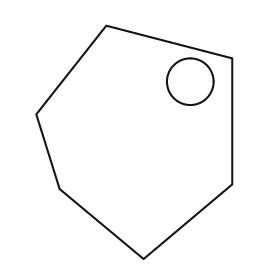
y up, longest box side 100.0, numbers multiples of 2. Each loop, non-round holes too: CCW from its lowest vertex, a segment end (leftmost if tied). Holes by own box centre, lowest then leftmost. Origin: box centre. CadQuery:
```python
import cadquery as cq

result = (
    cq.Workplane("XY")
    .moveTo(4.0, -50.0)
    .lineTo(42.0, -18.0)
    .lineTo(42.0, 36.0)
    .lineTo(-12.0, 50.0)
    .lineTo(-42.0, 12.0)
    .lineTo(-32.0, -20.0)
    .close()
    .moveTo(24.0, 26.0)
    .circle(10.0)
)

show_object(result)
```